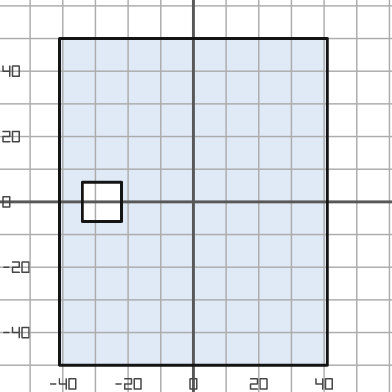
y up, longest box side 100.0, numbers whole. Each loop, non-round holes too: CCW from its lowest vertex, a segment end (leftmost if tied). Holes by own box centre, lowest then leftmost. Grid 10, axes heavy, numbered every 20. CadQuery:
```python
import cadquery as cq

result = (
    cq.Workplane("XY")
    .moveTo(-41.0, -50.0)
    .lineTo(41.0, -50.0)
    .lineTo(41.0, 50.0)
    .lineTo(-41.0, 50.0)
    .close()
    .moveTo(-34.0, -6.0)
    .lineTo(-22.0, -6.0)
    .lineTo(-22.0, 6.0)
    .lineTo(-34.0, 6.0)
    .close()
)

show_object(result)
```